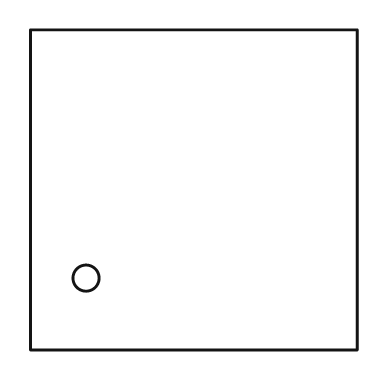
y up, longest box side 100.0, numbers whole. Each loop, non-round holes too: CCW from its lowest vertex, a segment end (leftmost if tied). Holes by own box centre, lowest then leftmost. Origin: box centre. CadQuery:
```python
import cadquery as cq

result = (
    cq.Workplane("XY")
    .moveTo(-50.0, -49.0)
    .lineTo(50.0, -49.0)
    .lineTo(50.0, 49.0)
    .lineTo(-50.0, 49.0)
    .close()
    .moveTo(-33.0, -27.0)
    .circle(4.0)
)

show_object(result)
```